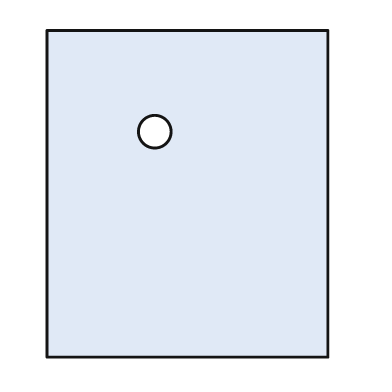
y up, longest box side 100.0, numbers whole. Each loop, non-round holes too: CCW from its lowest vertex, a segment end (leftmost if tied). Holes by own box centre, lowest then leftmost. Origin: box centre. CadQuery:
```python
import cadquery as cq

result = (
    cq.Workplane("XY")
    .moveTo(-43.0, -50.0)
    .lineTo(43.0, -50.0)
    .lineTo(43.0, 50.0)
    .lineTo(-43.0, 50.0)
    .close()
    .moveTo(-10.0, 19.0)
    .circle(5.0)
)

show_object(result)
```